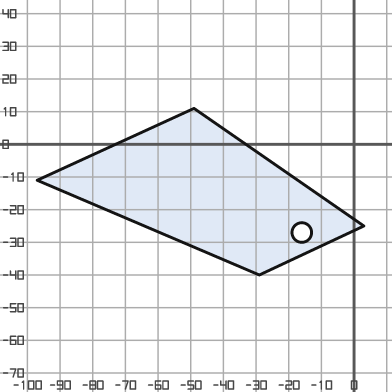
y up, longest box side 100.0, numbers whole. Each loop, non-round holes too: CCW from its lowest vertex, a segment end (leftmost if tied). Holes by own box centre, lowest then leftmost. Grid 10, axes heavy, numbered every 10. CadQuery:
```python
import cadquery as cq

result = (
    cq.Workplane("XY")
    .moveTo(-29.0, -40.0)
    .lineTo(3.0, -25.0)
    .lineTo(-49.0, 11.0)
    .lineTo(-97.0, -11.0)
    .close()
    .moveTo(-16.0, -27.0)
    .circle(3.0)
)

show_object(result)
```